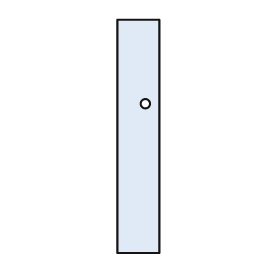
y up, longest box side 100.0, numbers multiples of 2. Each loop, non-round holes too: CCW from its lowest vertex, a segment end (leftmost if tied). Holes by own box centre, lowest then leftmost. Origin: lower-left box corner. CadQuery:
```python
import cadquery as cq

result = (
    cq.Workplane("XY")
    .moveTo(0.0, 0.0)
    .lineTo(18.0, 0.0)
    .lineTo(18.0, 100.0)
    .lineTo(0.0, 100.0)
    .close()
    .moveTo(12.0, 64.0)
    .circle(2.0)
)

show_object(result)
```